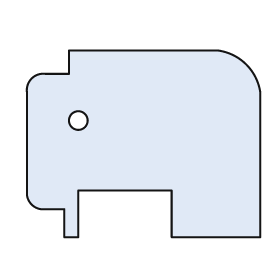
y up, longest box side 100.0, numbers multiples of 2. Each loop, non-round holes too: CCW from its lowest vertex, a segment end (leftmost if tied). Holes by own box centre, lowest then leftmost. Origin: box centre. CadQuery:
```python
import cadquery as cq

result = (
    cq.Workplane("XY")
    .moveTo(-34.0, -40.0)
    .lineTo(-28.0, -40.0)
    .lineTo(-28.0, -20.0)
    .lineTo(12.0, -20.0)
    .lineTo(12.0, -40.0)
    .lineTo(50.0, -40.0)
    .lineTo(50.0, 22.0)
    .threePointArc((44.0, 34.0), (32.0, 40.0))
    .lineTo(-32.0, 40.0)
    .lineTo(-32.0, 30.0)
    .lineTo(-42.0, 30.0)
    .threePointArc((-48.0, 28.0), (-50.0, 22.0))
    .lineTo(-50.0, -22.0)
    .threePointArc((-48.0, -26.0), (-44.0, -28.0))
    .lineTo(-34.0, -28.0)
    .close()
    .moveTo(-28.0, 10.0)
    .circle(4.0)
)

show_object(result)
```